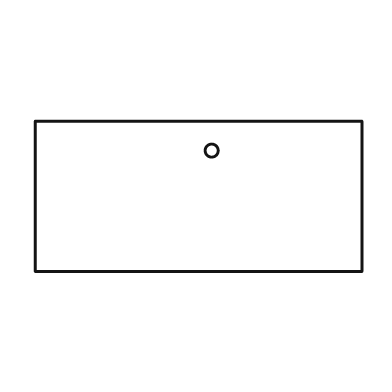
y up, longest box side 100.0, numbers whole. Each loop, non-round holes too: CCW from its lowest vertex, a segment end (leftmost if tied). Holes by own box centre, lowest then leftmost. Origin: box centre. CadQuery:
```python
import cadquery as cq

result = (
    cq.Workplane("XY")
    .moveTo(-50.0, -23.0)
    .lineTo(50.0, -23.0)
    .lineTo(50.0, 23.0)
    .lineTo(-50.0, 23.0)
    .close()
    .moveTo(4.0, 14.0)
    .circle(2.0)
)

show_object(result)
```